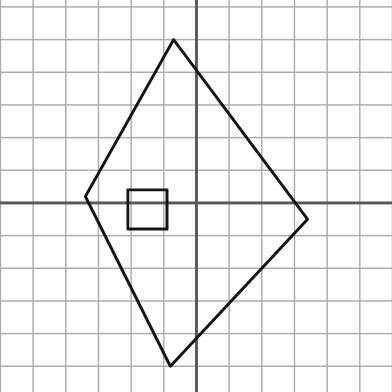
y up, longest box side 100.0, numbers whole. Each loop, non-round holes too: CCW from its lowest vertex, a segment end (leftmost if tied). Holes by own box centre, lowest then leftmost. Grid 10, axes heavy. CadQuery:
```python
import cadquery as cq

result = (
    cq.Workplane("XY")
    .moveTo(-8.0, -50.0)
    .lineTo(34.0, -5.0)
    .lineTo(-7.0, 50.0)
    .lineTo(-34.0, 2.0)
    .close()
    .moveTo(-21.0, -8.0)
    .lineTo(-9.0, -8.0)
    .lineTo(-9.0, 4.0)
    .lineTo(-21.0, 4.0)
    .close()
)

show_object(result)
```